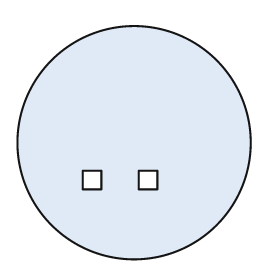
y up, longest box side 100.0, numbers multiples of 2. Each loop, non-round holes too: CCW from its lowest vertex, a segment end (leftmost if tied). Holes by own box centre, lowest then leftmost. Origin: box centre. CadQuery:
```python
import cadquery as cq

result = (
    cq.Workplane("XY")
    .moveTo(0.0, 0.0)
    .circle(50.0)
    .moveTo(-22.0, -20.0)
    .lineTo(-14.0, -20.0)
    .lineTo(-14.0, -12.0)
    .lineTo(-22.0, -12.0)
    .close()
    .moveTo(2.0, -20.0)
    .lineTo(10.0, -20.0)
    .lineTo(10.0, -12.0)
    .lineTo(2.0, -12.0)
    .close()
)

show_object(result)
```